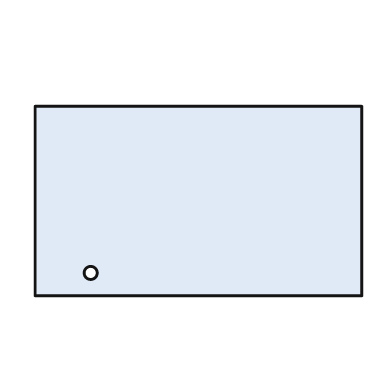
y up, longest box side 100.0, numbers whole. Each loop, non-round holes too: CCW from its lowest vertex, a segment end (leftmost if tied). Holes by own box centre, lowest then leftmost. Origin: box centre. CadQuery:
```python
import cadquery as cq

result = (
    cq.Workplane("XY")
    .moveTo(-50.0, -29.0)
    .lineTo(50.0, -29.0)
    .lineTo(50.0, 29.0)
    .lineTo(-50.0, 29.0)
    .close()
    .moveTo(-33.0, -22.0)
    .circle(2.0)
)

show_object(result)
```